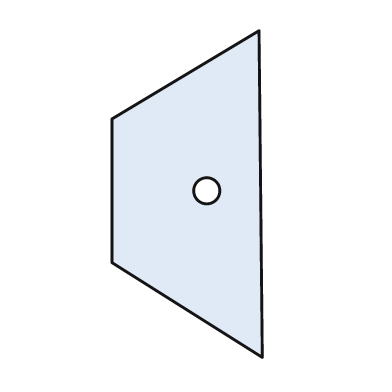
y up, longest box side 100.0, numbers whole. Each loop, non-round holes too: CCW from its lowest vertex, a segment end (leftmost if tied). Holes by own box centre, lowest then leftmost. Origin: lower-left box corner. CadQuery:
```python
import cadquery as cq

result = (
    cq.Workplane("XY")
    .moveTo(46.0, 0.0)
    .lineTo(45.0, 100.0)
    .lineTo(0.0, 73.0)
    .lineTo(0.0, 29.0)
    .close()
    .moveTo(29.0, 51.0)
    .circle(4.0)
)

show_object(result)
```